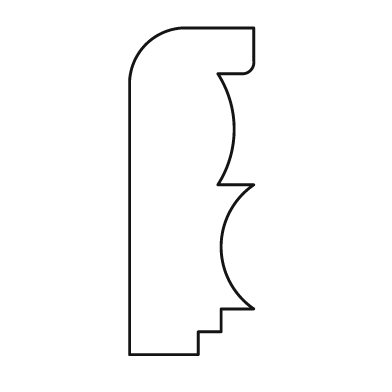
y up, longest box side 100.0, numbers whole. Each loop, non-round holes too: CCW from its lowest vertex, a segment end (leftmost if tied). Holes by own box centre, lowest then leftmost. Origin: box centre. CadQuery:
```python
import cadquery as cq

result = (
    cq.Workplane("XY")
    .moveTo(-19.0, -50.0)
    .lineTo(2.0, -50.0)
    .lineTo(2.0, -43.0)
    .lineTo(9.0, -43.0)
    .lineTo(9.0, -36.0)
    .lineTo(19.0, -36.0)
    .threePointArc((9.0, -17.0), (19.0, 2.0))
    .lineTo(8.0, 2.0)
    .threePointArc((13.0, 19.0), (8.0, 36.0))
    .lineTo(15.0, 36.0)
    .threePointArc((18.0, 37.0), (19.0, 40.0))
    .lineTo(19.0, 50.0)
    .lineTo(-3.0, 50.0)
    .threePointArc((-14.0, 45.0), (-19.0, 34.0))
    .close()
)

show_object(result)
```